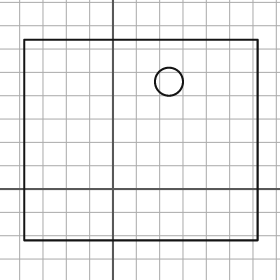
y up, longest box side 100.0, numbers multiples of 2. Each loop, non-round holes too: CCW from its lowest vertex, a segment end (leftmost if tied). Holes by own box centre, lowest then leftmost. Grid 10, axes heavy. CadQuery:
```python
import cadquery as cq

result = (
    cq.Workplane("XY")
    .moveTo(-38.0, -22.0)
    .lineTo(62.0, -22.0)
    .lineTo(62.0, 64.0)
    .lineTo(-38.0, 64.0)
    .close()
    .moveTo(24.0, 46.0)
    .circle(6.0)
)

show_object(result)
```